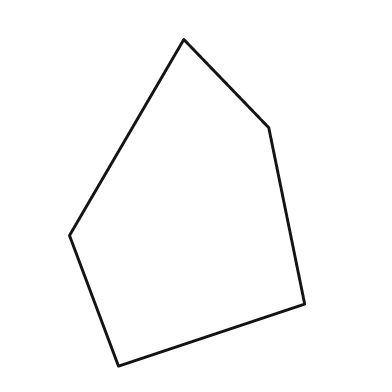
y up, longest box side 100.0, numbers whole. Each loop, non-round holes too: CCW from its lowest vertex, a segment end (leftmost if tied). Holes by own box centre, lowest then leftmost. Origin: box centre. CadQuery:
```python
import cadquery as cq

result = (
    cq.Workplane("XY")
    .moveTo(-21.0, -50.0)
    .lineTo(36.0, -31.0)
    .lineTo(25.0, 23.0)
    .lineTo(-1.0, 50.0)
    .lineTo(-36.0, -10.0)
    .close()
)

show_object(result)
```